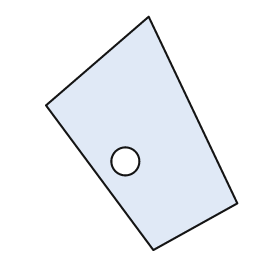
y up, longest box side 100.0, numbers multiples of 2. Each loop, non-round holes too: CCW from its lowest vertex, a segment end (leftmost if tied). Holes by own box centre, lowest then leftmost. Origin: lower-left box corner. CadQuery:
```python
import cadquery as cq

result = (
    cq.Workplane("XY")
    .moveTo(46.0, 0.0)
    .lineTo(82.0, 20.0)
    .lineTo(44.0, 100.0)
    .lineTo(0.0, 62.0)
    .close()
    .moveTo(34.0, 38.0)
    .circle(6.0)
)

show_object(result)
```